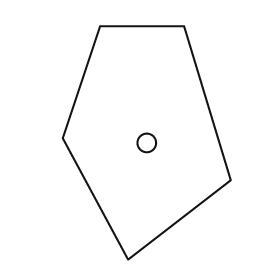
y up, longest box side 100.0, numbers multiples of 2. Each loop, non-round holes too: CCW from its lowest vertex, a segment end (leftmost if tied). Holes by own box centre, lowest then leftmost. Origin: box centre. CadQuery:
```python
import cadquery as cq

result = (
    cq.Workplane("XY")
    .moveTo(-8.0, -50.0)
    .lineTo(36.0, -16.0)
    .lineTo(16.0, 50.0)
    .lineTo(-20.0, 50.0)
    .lineTo(-36.0, 2.0)
    .close()
    .moveTo(0.0, 0.0)
    .circle(4.0)
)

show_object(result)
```